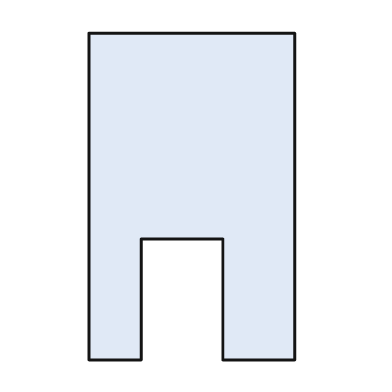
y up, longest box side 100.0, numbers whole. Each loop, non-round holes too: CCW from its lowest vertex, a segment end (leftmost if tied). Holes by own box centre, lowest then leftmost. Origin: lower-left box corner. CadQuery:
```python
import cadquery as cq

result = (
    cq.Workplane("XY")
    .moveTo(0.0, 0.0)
    .lineTo(16.0, 0.0)
    .lineTo(16.0, 37.0)
    .lineTo(41.0, 37.0)
    .lineTo(41.0, 0.0)
    .lineTo(63.0, 0.0)
    .lineTo(63.0, 100.0)
    .lineTo(0.0, 100.0)
    .close()
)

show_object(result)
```